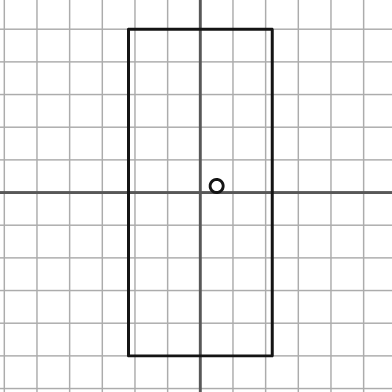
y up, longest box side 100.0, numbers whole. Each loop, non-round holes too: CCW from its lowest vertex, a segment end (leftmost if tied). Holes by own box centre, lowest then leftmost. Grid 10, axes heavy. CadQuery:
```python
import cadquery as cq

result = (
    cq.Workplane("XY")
    .moveTo(-22.0, -50.0)
    .lineTo(22.0, -50.0)
    .lineTo(22.0, 50.0)
    .lineTo(-22.0, 50.0)
    .close()
    .moveTo(5.0, 2.0)
    .circle(2.0)
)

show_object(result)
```